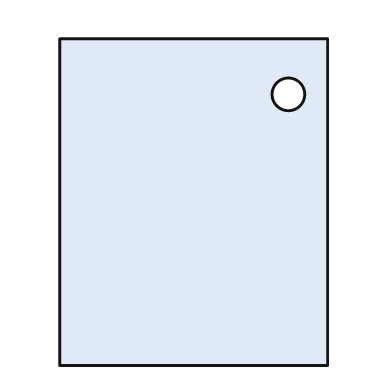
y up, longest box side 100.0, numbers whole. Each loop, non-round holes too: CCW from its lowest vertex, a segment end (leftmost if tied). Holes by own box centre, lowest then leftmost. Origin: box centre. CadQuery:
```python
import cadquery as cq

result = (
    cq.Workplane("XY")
    .moveTo(-41.0, -50.0)
    .lineTo(41.0, -50.0)
    .lineTo(41.0, 50.0)
    .lineTo(-41.0, 50.0)
    .close()
    .moveTo(29.0, 33.0)
    .circle(5.0)
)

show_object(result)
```